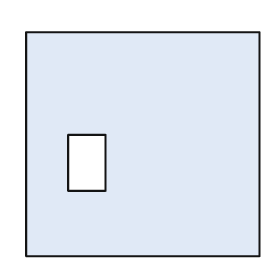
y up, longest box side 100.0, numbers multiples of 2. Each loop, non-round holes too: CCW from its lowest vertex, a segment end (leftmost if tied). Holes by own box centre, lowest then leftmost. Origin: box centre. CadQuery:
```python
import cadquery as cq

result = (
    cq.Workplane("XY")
    .moveTo(-50.0, -48.0)
    .lineTo(50.0, -48.0)
    .lineTo(50.0, 48.0)
    .lineTo(-50.0, 48.0)
    .close()
    .moveTo(-32.0, -20.0)
    .lineTo(-16.0, -20.0)
    .lineTo(-16.0, 4.0)
    .lineTo(-32.0, 4.0)
    .close()
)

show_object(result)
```